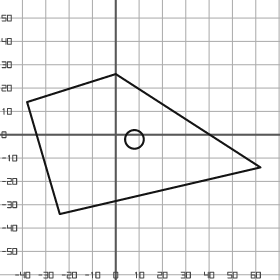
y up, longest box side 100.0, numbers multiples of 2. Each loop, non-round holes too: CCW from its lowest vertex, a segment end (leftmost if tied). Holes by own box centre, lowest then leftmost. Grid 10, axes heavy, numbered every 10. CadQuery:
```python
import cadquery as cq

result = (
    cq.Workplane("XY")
    .moveTo(-24.0, -34.0)
    .lineTo(62.0, -14.0)
    .lineTo(0.0, 26.0)
    .lineTo(-38.0, 14.0)
    .close()
    .moveTo(8.0, -2.0)
    .circle(4.0)
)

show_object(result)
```